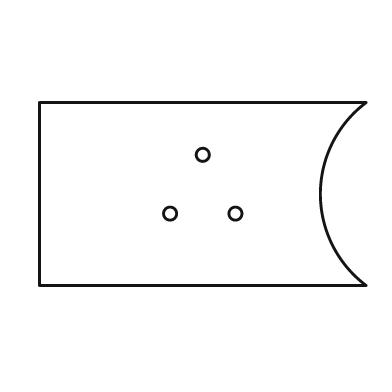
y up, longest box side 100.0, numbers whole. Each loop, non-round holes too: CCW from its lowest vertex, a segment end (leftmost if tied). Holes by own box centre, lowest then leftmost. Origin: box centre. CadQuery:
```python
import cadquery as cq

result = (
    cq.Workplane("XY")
    .moveTo(-50.0, -28.0)
    .lineTo(50.0, -28.0)
    .threePointArc((36.0, 0.0), (50.0, 28.0))
    .lineTo(-50.0, 28.0)
    .close()
    .moveTo(-10.0, -6.0)
    .circle(2.0)
    .moveTo(10.0, -6.0)
    .circle(2.0)
    .moveTo(0.0, 12.0)
    .circle(2.0)
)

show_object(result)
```